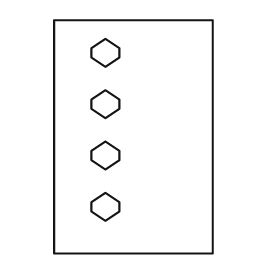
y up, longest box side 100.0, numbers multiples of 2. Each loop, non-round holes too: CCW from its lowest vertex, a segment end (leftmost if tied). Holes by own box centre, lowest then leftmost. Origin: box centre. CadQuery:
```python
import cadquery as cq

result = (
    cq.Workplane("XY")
    .moveTo(-34.0, -50.0)
    .lineTo(34.0, -50.0)
    .lineTo(34.0, 50.0)
    .lineTo(-34.0, 50.0)
    .close()
    .moveTo(-12.0, -36.0)
    .lineTo(-6.0, -32.0)
    .lineTo(-6.0, -28.0)
    .lineTo(-12.0, -24.0)
    .lineTo(-18.0, -28.0)
    .lineTo(-18.0, -32.0)
    .close()
    .moveTo(-12.0, -14.0)
    .lineTo(-6.0, -10.0)
    .lineTo(-6.0, -6.0)
    .lineTo(-12.0, -2.0)
    .lineTo(-18.0, -6.0)
    .lineTo(-18.0, -10.0)
    .close()
    .moveTo(-12.0, 8.0)
    .lineTo(-6.0, 12.0)
    .lineTo(-6.0, 16.0)
    .lineTo(-12.0, 20.0)
    .lineTo(-18.0, 16.0)
    .lineTo(-18.0, 12.0)
    .close()
    .moveTo(-12.0, 30.0)
    .lineTo(-6.0, 34.0)
    .lineTo(-6.0, 38.0)
    .lineTo(-12.0, 42.0)
    .lineTo(-18.0, 38.0)
    .lineTo(-18.0, 34.0)
    .close()
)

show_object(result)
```